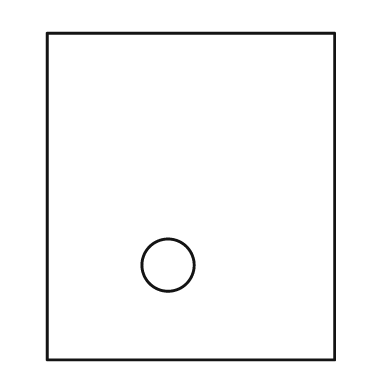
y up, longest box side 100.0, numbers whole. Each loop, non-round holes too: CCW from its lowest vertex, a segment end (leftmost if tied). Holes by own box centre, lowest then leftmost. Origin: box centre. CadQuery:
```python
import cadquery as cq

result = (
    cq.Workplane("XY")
    .moveTo(-44.0, -50.0)
    .lineTo(44.0, -50.0)
    .lineTo(44.0, 50.0)
    .lineTo(-44.0, 50.0)
    .close()
    .moveTo(-7.0, -21.0)
    .circle(8.0)
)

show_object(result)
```